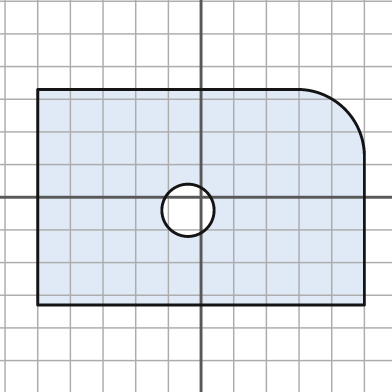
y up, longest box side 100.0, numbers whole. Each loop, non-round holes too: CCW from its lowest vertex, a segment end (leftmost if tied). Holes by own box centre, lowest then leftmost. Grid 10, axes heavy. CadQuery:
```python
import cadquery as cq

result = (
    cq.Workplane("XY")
    .moveTo(-50.0, -33.0)
    .lineTo(50.0, -33.0)
    .lineTo(50.0, 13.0)
    .threePointArc((44.0, 27.0), (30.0, 33.0))
    .lineTo(-50.0, 33.0)
    .close()
    .moveTo(-4.0, -4.0)
    .circle(8.0)
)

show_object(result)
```